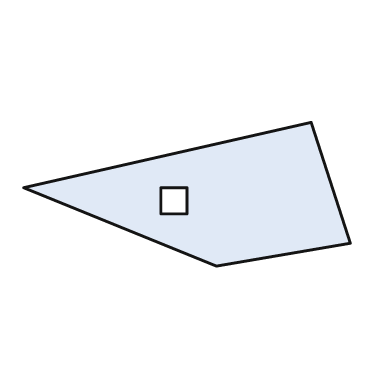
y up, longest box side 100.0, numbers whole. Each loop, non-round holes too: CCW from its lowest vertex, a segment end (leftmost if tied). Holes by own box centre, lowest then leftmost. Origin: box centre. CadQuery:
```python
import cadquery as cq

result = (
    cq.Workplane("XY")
    .moveTo(9.0, -22.0)
    .lineTo(50.0, -15.0)
    .lineTo(38.0, 22.0)
    .lineTo(-50.0, 2.0)
    .close()
    .moveTo(-8.0, -6.0)
    .lineTo(0.0, -6.0)
    .lineTo(0.0, 2.0)
    .lineTo(-8.0, 2.0)
    .close()
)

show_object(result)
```